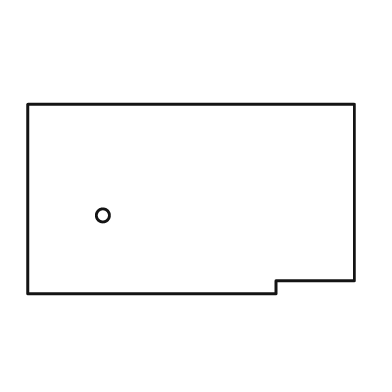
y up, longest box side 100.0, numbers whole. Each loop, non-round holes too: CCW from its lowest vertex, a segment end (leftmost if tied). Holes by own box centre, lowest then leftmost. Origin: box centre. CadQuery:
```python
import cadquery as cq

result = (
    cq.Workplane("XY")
    .moveTo(-50.0, -29.0)
    .lineTo(26.0, -29.0)
    .lineTo(26.0, -25.0)
    .lineTo(50.0, -25.0)
    .lineTo(50.0, 29.0)
    .lineTo(-50.0, 29.0)
    .close()
    .moveTo(-27.0, -5.0)
    .circle(2.0)
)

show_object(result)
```